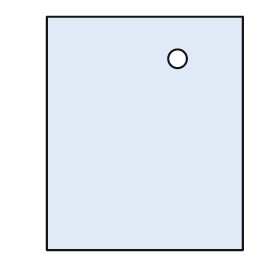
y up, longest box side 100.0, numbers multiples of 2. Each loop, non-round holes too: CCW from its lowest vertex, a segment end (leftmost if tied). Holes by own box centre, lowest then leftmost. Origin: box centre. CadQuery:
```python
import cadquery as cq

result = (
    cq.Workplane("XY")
    .moveTo(-42.0, -50.0)
    .lineTo(42.0, -50.0)
    .lineTo(42.0, 50.0)
    .lineTo(-42.0, 50.0)
    .close()
    .moveTo(14.0, 32.0)
    .circle(4.0)
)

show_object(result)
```